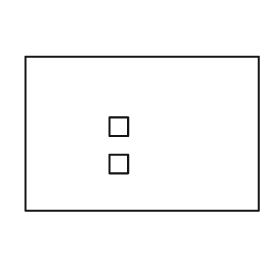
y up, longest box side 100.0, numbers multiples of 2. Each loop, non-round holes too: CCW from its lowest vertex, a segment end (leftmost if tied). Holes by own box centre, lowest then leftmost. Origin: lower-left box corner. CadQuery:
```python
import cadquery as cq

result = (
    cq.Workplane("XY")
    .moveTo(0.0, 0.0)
    .lineTo(100.0, 0.0)
    .lineTo(100.0, 66.0)
    .lineTo(0.0, 66.0)
    .close()
    .moveTo(36.0, 16.0)
    .lineTo(44.0, 16.0)
    .lineTo(44.0, 24.0)
    .lineTo(36.0, 24.0)
    .close()
    .moveTo(36.0, 32.0)
    .lineTo(44.0, 32.0)
    .lineTo(44.0, 40.0)
    .lineTo(36.0, 40.0)
    .close()
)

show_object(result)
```